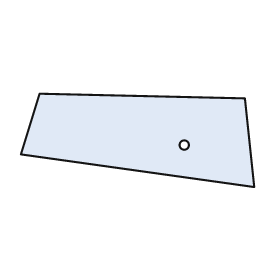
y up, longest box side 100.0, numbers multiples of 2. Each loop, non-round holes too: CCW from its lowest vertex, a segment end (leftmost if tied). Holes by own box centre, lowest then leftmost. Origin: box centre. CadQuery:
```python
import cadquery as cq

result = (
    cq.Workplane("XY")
    .moveTo(50.0, -20.0)
    .lineTo(46.0, 18.0)
    .lineTo(-42.0, 20.0)
    .lineTo(-50.0, -6.0)
    .close()
    .moveTo(20.0, -2.0)
    .circle(2.0)
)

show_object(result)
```